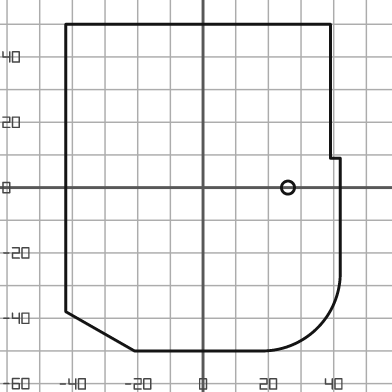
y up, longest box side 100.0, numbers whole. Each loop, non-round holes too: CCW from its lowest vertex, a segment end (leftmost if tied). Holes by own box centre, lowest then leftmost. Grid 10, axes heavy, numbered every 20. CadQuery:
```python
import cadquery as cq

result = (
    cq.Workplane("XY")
    .moveTo(-21.0, -50.0)
    .lineTo(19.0, -50.0)
    .threePointArc((35.0, -43.0), (42.0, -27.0))
    .lineTo(42.0, 9.0)
    .lineTo(39.0, 9.0)
    .lineTo(39.0, 50.0)
    .lineTo(-42.0, 50.0)
    .lineTo(-42.0, -38.0)
    .close()
    .moveTo(26.0, 0.0)
    .circle(2.0)
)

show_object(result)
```